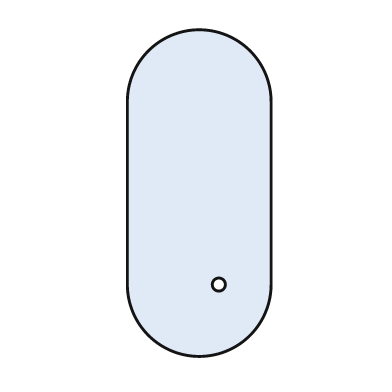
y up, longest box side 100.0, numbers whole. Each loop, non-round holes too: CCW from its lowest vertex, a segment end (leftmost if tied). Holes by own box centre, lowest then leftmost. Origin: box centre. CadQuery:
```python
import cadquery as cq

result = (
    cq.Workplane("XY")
    .moveTo(-22.0, -28.0)
    .threePointArc((0.0, -50.0), (22.0, -28.0))
    .lineTo(22.0, 28.0)
    .threePointArc((0.0, 50.0), (-22.0, 28.0))
    .close()
    .moveTo(6.0, -28.0)
    .circle(2.0)
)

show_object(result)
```